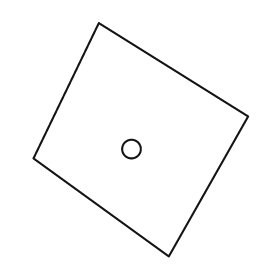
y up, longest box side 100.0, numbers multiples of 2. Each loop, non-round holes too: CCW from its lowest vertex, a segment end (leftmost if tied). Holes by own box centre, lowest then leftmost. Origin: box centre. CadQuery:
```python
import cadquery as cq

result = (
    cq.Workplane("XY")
    .moveTo(12.0, -50.0)
    .lineTo(46.0, 10.0)
    .lineTo(-18.0, 50.0)
    .lineTo(-46.0, -8.0)
    .close()
    .moveTo(-4.0, -4.0)
    .circle(4.0)
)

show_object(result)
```